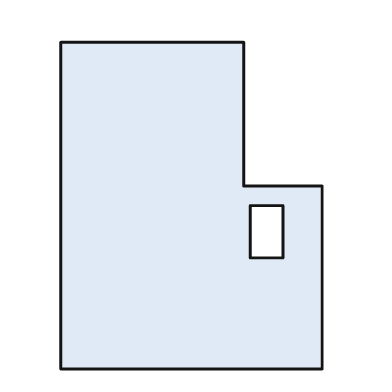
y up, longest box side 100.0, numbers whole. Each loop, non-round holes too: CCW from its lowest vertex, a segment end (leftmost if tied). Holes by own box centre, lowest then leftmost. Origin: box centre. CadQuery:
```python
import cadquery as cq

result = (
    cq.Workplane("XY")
    .moveTo(-40.0, -50.0)
    .lineTo(40.0, -50.0)
    .lineTo(40.0, 6.0)
    .lineTo(16.0, 6.0)
    .lineTo(16.0, 50.0)
    .lineTo(-40.0, 50.0)
    .close()
    .moveTo(18.0, -16.0)
    .lineTo(28.0, -16.0)
    .lineTo(28.0, 0.0)
    .lineTo(18.0, 0.0)
    .close()
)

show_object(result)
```